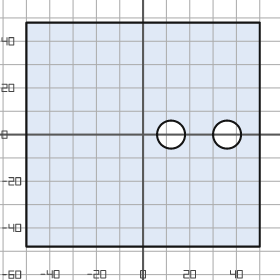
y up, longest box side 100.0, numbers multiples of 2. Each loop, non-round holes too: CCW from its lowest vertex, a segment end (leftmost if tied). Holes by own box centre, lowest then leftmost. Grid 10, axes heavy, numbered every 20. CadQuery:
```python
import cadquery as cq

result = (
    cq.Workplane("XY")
    .moveTo(-50.0, -48.0)
    .lineTo(50.0, -48.0)
    .lineTo(50.0, 48.0)
    .lineTo(-50.0, 48.0)
    .close()
    .moveTo(12.0, 0.0)
    .circle(6.0)
    .moveTo(36.0, 0.0)
    .circle(6.0)
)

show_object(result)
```